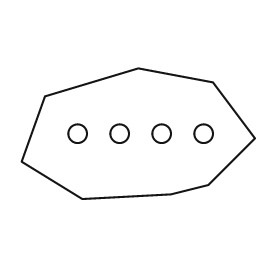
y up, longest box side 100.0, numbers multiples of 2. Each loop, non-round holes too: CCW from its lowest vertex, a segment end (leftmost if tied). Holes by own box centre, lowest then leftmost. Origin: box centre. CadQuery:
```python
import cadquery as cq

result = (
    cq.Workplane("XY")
    .moveTo(-24.0, -28.0)
    .lineTo(14.0, -26.0)
    .lineTo(30.0, -22.0)
    .lineTo(50.0, -2.0)
    .lineTo(32.0, 22.0)
    .lineTo(0.0, 28.0)
    .lineTo(-40.0, 16.0)
    .lineTo(-50.0, -12.0)
    .close()
    .moveTo(-26.0, 0.0)
    .circle(4.0)
    .moveTo(-8.0, 0.0)
    .circle(4.0)
    .moveTo(10.0, 0.0)
    .circle(4.0)
    .moveTo(28.0, 0.0)
    .circle(4.0)
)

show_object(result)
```